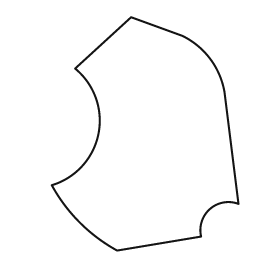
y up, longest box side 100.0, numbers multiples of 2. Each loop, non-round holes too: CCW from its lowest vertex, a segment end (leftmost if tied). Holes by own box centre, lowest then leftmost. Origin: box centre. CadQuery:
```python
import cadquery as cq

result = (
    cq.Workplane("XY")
    .moveTo(-12.0, -50.0)
    .lineTo(24.0, -44.0)
    .threePointArc((28.0, -32.0), (40.0, -30.0))
    .lineTo(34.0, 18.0)
    .threePointArc((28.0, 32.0), (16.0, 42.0))
    .lineTo(-6.0, 50.0)
    .lineTo(-30.0, 28.0)
    .threePointArc((-20.0, 0.0), (-40.0, -22.0))
    .threePointArc((-28.0, -38.0), (-12.0, -50.0))
    .close()
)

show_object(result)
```